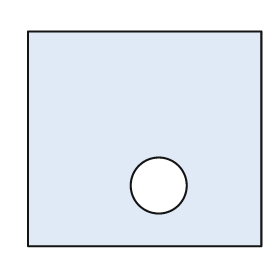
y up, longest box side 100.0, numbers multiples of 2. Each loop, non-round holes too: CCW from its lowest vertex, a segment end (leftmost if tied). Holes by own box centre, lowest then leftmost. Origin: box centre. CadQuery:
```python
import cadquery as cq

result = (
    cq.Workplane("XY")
    .moveTo(-50.0, -46.0)
    .lineTo(50.0, -46.0)
    .lineTo(50.0, 46.0)
    .lineTo(-50.0, 46.0)
    .close()
    .moveTo(6.0, -20.0)
    .circle(12.0)
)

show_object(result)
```